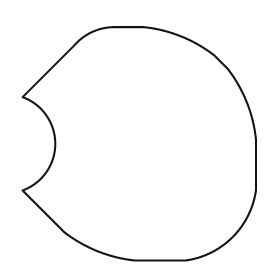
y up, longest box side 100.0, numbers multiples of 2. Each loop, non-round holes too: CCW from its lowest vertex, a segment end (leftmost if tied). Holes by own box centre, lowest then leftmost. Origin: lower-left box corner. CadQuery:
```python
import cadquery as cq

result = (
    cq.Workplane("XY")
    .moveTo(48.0, 0.0)
    .lineTo(70.0, 0.0)
    .threePointArc((90.0, 10.0), (100.0, 30.0))
    .lineTo(100.0, 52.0)
    .threePointArc((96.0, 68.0), (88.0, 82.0))
    .lineTo(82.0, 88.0)
    .threePointArc((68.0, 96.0), (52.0, 100.0))
    .lineTo(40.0, 100.0)
    .threePointArc((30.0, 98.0), (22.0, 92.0))
    .lineTo(0.0, 70.0)
    .threePointArc((14.0, 50.0), (0.0, 30.0))
    .lineTo(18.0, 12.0)
    .threePointArc((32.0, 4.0), (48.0, 0.0))
    .close()
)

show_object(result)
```